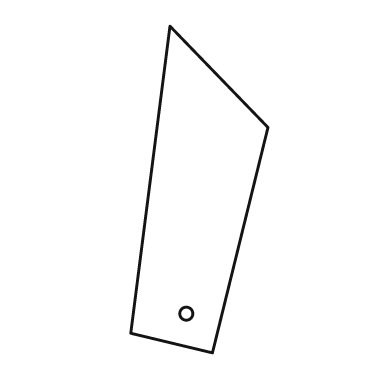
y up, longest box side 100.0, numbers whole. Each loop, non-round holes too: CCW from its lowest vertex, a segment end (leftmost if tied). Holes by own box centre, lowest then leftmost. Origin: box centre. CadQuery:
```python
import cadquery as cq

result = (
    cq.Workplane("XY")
    .moveTo(4.0, -50.0)
    .lineTo(21.0, 19.0)
    .lineTo(-9.0, 50.0)
    .lineTo(-21.0, -44.0)
    .close()
    .moveTo(-4.0, -38.0)
    .circle(2.0)
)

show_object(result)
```